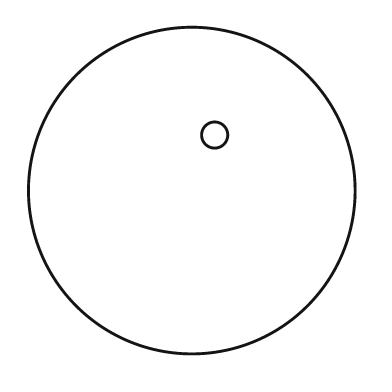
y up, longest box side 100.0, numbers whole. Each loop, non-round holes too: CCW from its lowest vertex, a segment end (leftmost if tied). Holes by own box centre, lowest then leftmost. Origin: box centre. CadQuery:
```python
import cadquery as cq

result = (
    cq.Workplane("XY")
    .moveTo(0.0, 0.0)
    .circle(50.0)
    .moveTo(7.0, 17.0)
    .circle(4.0)
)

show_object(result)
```